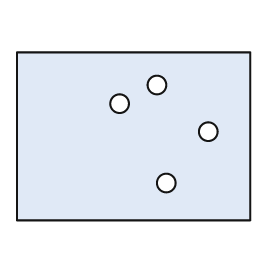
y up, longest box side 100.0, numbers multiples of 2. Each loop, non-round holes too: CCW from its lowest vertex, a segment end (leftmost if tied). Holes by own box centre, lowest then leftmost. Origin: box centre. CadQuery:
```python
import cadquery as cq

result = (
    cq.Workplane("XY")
    .moveTo(-50.0, -36.0)
    .lineTo(50.0, -36.0)
    .lineTo(50.0, 36.0)
    .lineTo(-50.0, 36.0)
    .close()
    .moveTo(14.0, -20.0)
    .circle(4.0)
    .moveTo(32.0, 2.0)
    .circle(4.0)
    .moveTo(-6.0, 14.0)
    .circle(4.0)
    .moveTo(10.0, 22.0)
    .circle(4.0)
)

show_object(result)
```